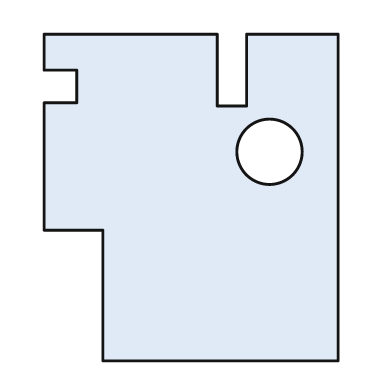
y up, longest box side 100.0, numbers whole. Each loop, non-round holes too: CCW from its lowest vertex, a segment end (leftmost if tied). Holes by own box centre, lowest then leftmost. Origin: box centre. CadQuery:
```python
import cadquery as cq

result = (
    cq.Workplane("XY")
    .moveTo(-27.0, -50.0)
    .lineTo(45.0, -50.0)
    .lineTo(45.0, 50.0)
    .lineTo(17.0, 50.0)
    .lineTo(17.0, 28.0)
    .lineTo(8.0, 28.0)
    .lineTo(8.0, 50.0)
    .lineTo(-45.0, 50.0)
    .lineTo(-45.0, 39.0)
    .lineTo(-35.0, 39.0)
    .lineTo(-35.0, 29.0)
    .lineTo(-45.0, 29.0)
    .lineTo(-45.0, -10.0)
    .lineTo(-27.0, -10.0)
    .close()
    .moveTo(24.0, 14.0)
    .circle(10.0)
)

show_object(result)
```